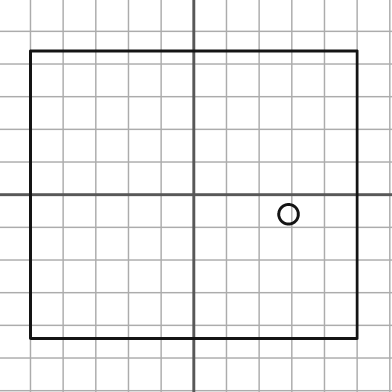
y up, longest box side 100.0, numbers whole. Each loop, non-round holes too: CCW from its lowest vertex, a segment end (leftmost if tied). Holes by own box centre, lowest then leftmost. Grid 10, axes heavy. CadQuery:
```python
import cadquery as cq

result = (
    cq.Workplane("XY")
    .moveTo(-50.0, -44.0)
    .lineTo(50.0, -44.0)
    .lineTo(50.0, 44.0)
    .lineTo(-50.0, 44.0)
    .close()
    .moveTo(29.0, -6.0)
    .circle(3.0)
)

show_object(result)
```